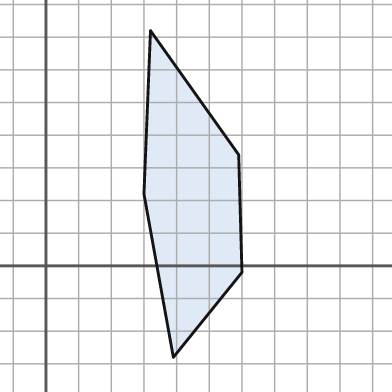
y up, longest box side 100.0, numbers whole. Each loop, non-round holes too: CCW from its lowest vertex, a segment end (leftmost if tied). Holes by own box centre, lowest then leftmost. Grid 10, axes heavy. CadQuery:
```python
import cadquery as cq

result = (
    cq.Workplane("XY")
    .moveTo(39.0, -28.0)
    .lineTo(60.0, -2.0)
    .lineTo(59.0, 34.0)
    .lineTo(32.0, 72.0)
    .lineTo(30.0, 22.0)
    .close()
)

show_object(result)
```